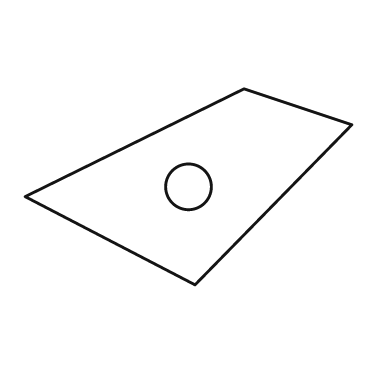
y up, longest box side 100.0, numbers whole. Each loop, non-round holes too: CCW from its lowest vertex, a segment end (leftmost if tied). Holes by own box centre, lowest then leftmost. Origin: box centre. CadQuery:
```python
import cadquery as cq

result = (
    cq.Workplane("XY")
    .moveTo(2.0, -30.0)
    .lineTo(50.0, 19.0)
    .lineTo(17.0, 30.0)
    .lineTo(-50.0, -3.0)
    .close()
    .moveTo(0.0, 0.0)
    .circle(7.0)
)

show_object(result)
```